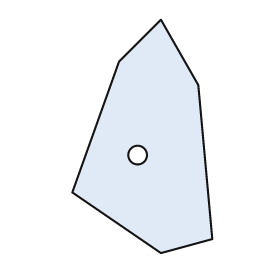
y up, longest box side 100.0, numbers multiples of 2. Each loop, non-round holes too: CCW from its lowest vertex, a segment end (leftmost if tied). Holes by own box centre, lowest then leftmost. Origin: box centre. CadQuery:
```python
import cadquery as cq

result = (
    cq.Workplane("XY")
    .moveTo(8.0, -50.0)
    .lineTo(30.0, -44.0)
    .lineTo(24.0, 22.0)
    .lineTo(8.0, 50.0)
    .lineTo(-10.0, 32.0)
    .lineTo(-30.0, -24.0)
    .close()
    .moveTo(-2.0, -8.0)
    .circle(4.0)
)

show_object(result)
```